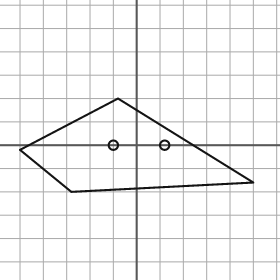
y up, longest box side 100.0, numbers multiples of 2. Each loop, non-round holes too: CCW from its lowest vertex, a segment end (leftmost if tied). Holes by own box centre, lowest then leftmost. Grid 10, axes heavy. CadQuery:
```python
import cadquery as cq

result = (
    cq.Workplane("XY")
    .moveTo(-28.0, -20.0)
    .lineTo(50.0, -16.0)
    .lineTo(-8.0, 20.0)
    .lineTo(-50.0, -2.0)
    .close()
    .moveTo(-10.0, 0.0)
    .circle(2.0)
    .moveTo(12.0, 0.0)
    .circle(2.0)
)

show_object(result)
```